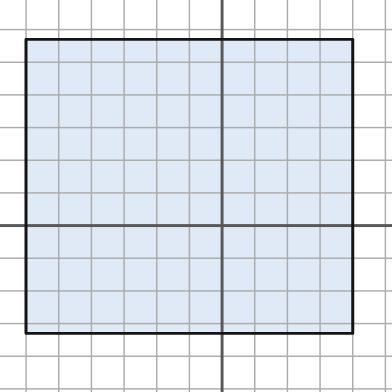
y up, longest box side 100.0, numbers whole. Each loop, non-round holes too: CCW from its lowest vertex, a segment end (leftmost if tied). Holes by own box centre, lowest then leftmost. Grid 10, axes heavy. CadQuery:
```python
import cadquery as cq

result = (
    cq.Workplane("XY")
    .moveTo(-60.0, -33.0)
    .lineTo(40.0, -33.0)
    .lineTo(40.0, 57.0)
    .lineTo(-60.0, 57.0)
    .close()
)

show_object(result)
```